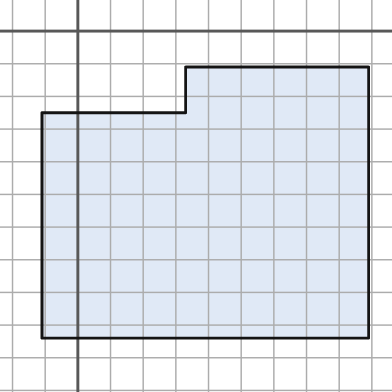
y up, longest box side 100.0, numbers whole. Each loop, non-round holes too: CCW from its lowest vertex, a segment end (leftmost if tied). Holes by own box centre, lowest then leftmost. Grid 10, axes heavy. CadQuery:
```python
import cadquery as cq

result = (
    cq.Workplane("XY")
    .moveTo(-11.0, -94.0)
    .lineTo(89.0, -94.0)
    .lineTo(89.0, -11.0)
    .lineTo(33.0, -11.0)
    .lineTo(33.0, -25.0)
    .lineTo(-11.0, -25.0)
    .close()
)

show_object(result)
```